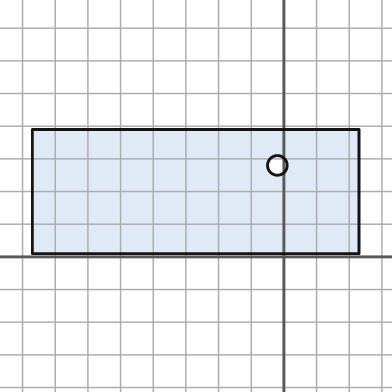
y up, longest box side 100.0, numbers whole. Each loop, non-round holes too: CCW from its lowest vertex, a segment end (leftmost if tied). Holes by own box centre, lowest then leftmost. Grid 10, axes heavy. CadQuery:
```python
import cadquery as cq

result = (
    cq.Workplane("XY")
    .moveTo(-77.0, 1.0)
    .lineTo(23.0, 1.0)
    .lineTo(23.0, 39.0)
    .lineTo(-77.0, 39.0)
    .close()
    .moveTo(-2.0, 28.0)
    .circle(3.0)
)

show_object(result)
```